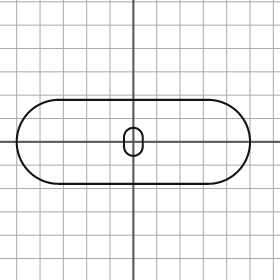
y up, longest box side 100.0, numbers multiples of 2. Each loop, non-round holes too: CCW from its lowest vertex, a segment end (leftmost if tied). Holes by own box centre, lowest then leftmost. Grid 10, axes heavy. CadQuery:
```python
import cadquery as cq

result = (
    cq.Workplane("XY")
    .moveTo(-32.0, -18.0)
    .lineTo(32.0, -18.0)
    .threePointArc((50.0, 0.0), (32.0, 18.0))
    .lineTo(-32.0, 18.0)
    .threePointArc((-50.0, 0.0), (-32.0, -18.0))
    .close()
    .moveTo(-4.0, -2.0)
    .threePointArc((0.0, -6.0), (4.0, -2.0))
    .lineTo(4.0, 2.0)
    .threePointArc((0.0, 6.0), (-4.0, 2.0))
    .close()
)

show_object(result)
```